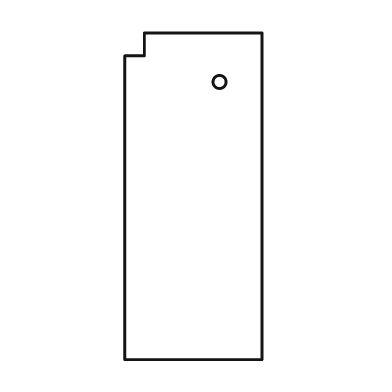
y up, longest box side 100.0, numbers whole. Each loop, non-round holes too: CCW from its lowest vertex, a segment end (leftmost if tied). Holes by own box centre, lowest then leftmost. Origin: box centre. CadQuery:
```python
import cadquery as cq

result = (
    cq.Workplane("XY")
    .moveTo(-21.0, -50.0)
    .lineTo(21.0, -50.0)
    .lineTo(21.0, 50.0)
    .lineTo(-15.0, 50.0)
    .lineTo(-15.0, 43.0)
    .lineTo(-21.0, 43.0)
    .close()
    .moveTo(8.0, 35.0)
    .circle(2.0)
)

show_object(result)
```